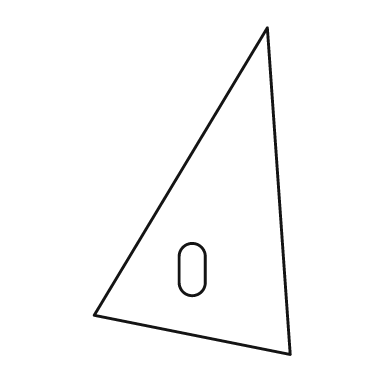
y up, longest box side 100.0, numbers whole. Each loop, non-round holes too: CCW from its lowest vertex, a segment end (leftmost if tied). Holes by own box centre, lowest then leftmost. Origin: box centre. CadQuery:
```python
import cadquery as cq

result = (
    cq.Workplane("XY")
    .moveTo(30.0, -50.0)
    .lineTo(23.0, 50.0)
    .lineTo(-30.0, -38.0)
    .close()
    .moveTo(-4.0, -28.0)
    .threePointArc((0.0, -32.0), (4.0, -28.0))
    .lineTo(4.0, -20.0)
    .threePointArc((0.0, -16.0), (-4.0, -20.0))
    .close()
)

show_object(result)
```